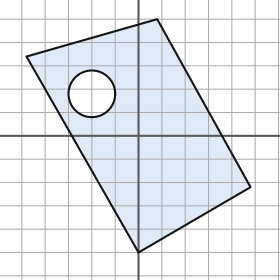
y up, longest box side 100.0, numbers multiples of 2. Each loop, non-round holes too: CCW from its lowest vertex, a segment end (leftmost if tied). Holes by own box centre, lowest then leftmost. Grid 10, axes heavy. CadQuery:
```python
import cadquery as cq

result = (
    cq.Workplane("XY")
    .moveTo(0.0, -50.0)
    .lineTo(48.0, -22.0)
    .lineTo(8.0, 50.0)
    .lineTo(-48.0, 34.0)
    .close()
    .moveTo(-20.0, 18.0)
    .circle(10.0)
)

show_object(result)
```